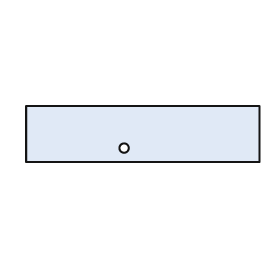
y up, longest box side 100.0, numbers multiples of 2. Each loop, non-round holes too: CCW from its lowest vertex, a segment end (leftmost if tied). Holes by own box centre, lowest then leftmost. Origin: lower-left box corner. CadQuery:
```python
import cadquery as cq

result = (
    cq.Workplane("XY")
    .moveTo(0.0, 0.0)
    .lineTo(100.0, 0.0)
    .lineTo(100.0, 24.0)
    .lineTo(0.0, 24.0)
    .close()
    .moveTo(42.0, 6.0)
    .circle(2.0)
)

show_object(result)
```